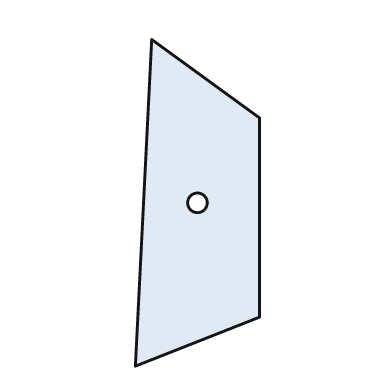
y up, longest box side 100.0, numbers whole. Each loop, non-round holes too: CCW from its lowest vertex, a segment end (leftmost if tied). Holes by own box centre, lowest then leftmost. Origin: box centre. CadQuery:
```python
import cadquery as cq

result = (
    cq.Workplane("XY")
    .moveTo(-19.0, -50.0)
    .lineTo(19.0, -35.0)
    .lineTo(19.0, 26.0)
    .lineTo(-14.0, 50.0)
    .close()
    .moveTo(0.0, 0.0)
    .circle(3.0)
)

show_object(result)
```